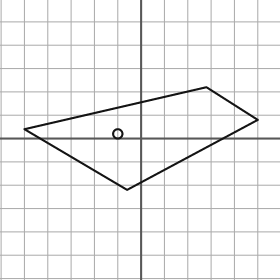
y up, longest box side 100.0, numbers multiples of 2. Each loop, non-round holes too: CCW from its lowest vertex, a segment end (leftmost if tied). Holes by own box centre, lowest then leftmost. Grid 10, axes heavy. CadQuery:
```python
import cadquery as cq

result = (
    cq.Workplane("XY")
    .moveTo(-6.0, -22.0)
    .lineTo(50.0, 8.0)
    .lineTo(28.0, 22.0)
    .lineTo(-50.0, 4.0)
    .close()
    .moveTo(-10.0, 2.0)
    .circle(2.0)
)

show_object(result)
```